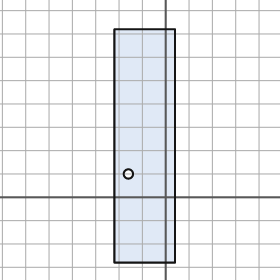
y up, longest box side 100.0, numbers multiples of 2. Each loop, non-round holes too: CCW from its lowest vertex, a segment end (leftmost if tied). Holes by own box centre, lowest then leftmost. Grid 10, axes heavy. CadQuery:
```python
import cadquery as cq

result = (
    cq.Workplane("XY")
    .moveTo(-22.0, -28.0)
    .lineTo(4.0, -28.0)
    .lineTo(4.0, 72.0)
    .lineTo(-22.0, 72.0)
    .close()
    .moveTo(-16.0, 10.0)
    .circle(2.0)
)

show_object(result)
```